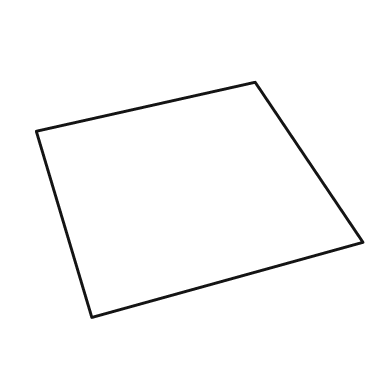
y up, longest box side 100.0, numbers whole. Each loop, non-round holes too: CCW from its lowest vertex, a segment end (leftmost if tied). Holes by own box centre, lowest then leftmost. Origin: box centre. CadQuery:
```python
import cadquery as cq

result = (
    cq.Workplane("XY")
    .moveTo(-33.0, -36.0)
    .lineTo(50.0, -13.0)
    .lineTo(17.0, 36.0)
    .lineTo(-50.0, 21.0)
    .close()
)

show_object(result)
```